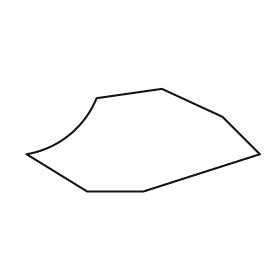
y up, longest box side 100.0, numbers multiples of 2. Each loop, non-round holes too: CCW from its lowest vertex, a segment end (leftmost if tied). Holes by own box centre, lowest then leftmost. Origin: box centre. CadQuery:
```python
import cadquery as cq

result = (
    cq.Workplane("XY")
    .moveTo(-24.0, -22.0)
    .lineTo(0.0, -22.0)
    .lineTo(50.0, -6.0)
    .lineTo(34.0, 10.0)
    .lineTo(8.0, 22.0)
    .lineTo(-20.0, 18.0)
    .threePointArc((-32.0, 2.0), (-50.0, -6.0))
    .close()
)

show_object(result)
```